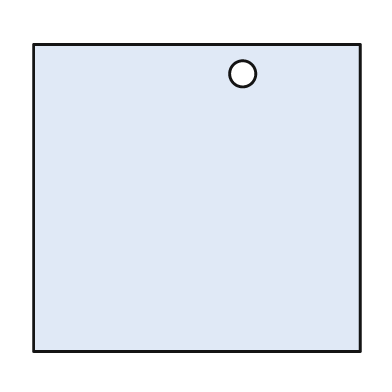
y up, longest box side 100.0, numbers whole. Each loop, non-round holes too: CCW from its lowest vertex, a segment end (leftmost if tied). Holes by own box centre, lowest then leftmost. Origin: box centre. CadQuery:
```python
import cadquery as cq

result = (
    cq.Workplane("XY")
    .moveTo(-50.0, -47.0)
    .lineTo(50.0, -47.0)
    .lineTo(50.0, 47.0)
    .lineTo(-50.0, 47.0)
    .close()
    .moveTo(14.0, 38.0)
    .circle(4.0)
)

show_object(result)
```